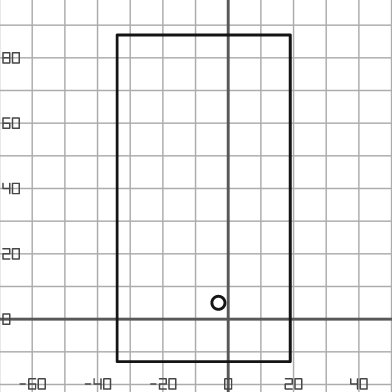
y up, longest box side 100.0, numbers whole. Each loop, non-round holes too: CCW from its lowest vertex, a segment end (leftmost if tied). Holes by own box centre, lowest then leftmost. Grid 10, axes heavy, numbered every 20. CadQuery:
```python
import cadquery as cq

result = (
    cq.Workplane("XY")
    .moveTo(-34.0, -13.0)
    .lineTo(19.0, -13.0)
    .lineTo(19.0, 87.0)
    .lineTo(-34.0, 87.0)
    .close()
    .moveTo(-3.0, 5.0)
    .circle(2.0)
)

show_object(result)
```